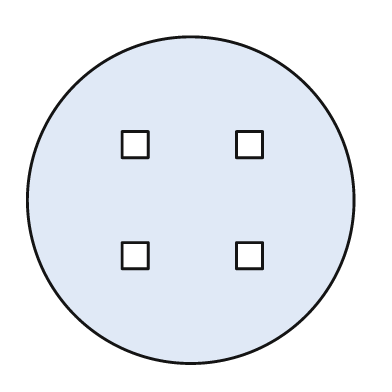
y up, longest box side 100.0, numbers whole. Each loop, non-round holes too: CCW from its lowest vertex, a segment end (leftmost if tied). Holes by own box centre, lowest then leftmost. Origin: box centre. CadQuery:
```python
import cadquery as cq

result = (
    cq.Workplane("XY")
    .moveTo(0.0, 0.0)
    .circle(50.0)
    .moveTo(-21.0, -21.0)
    .lineTo(-13.0, -21.0)
    .lineTo(-13.0, -13.0)
    .lineTo(-21.0, -13.0)
    .close()
    .moveTo(14.0, -21.0)
    .lineTo(22.0, -21.0)
    .lineTo(22.0, -13.0)
    .lineTo(14.0, -13.0)
    .close()
    .moveTo(-21.0, 13.0)
    .lineTo(-13.0, 13.0)
    .lineTo(-13.0, 21.0)
    .lineTo(-21.0, 21.0)
    .close()
    .moveTo(14.0, 13.0)
    .lineTo(22.0, 13.0)
    .lineTo(22.0, 21.0)
    .lineTo(14.0, 21.0)
    .close()
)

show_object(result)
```